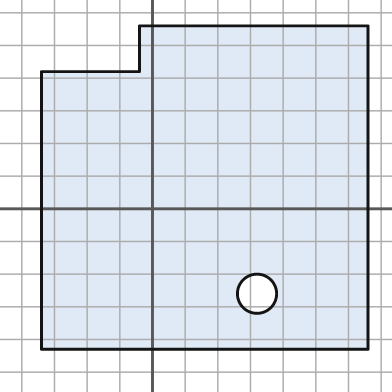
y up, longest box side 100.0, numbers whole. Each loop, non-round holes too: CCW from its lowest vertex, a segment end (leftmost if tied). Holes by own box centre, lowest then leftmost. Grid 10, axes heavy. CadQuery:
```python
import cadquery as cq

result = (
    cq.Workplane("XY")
    .moveTo(-34.0, -43.0)
    .lineTo(66.0, -43.0)
    .lineTo(66.0, 56.0)
    .lineTo(-4.0, 56.0)
    .lineTo(-4.0, 42.0)
    .lineTo(-34.0, 42.0)
    .close()
    .moveTo(32.0, -26.0)
    .circle(6.0)
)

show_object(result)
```